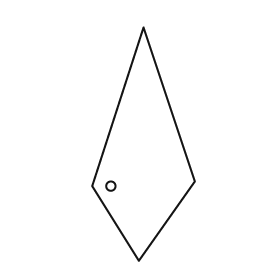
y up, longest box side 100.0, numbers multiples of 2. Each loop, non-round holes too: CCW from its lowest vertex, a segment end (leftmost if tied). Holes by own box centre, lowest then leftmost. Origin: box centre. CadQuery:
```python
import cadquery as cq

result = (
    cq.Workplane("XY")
    .moveTo(-2.0, -50.0)
    .lineTo(22.0, -16.0)
    .lineTo(0.0, 50.0)
    .lineTo(-22.0, -18.0)
    .close()
    .moveTo(-14.0, -18.0)
    .circle(2.0)
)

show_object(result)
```